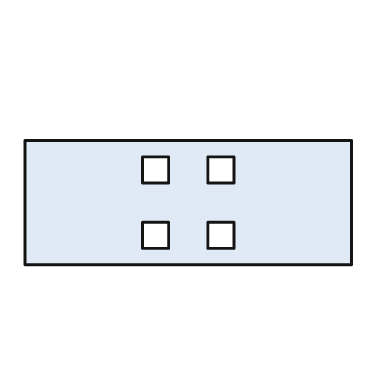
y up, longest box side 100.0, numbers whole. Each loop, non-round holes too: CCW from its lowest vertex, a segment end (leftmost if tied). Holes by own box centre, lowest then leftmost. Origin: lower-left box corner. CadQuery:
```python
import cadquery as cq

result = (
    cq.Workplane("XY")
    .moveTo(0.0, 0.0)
    .lineTo(100.0, 0.0)
    .lineTo(100.0, 38.0)
    .lineTo(0.0, 38.0)
    .close()
    .moveTo(36.0, 5.0)
    .lineTo(44.0, 5.0)
    .lineTo(44.0, 13.0)
    .lineTo(36.0, 13.0)
    .close()
    .moveTo(56.0, 5.0)
    .lineTo(64.0, 5.0)
    .lineTo(64.0, 13.0)
    .lineTo(56.0, 13.0)
    .close()
    .moveTo(36.0, 25.0)
    .lineTo(44.0, 25.0)
    .lineTo(44.0, 33.0)
    .lineTo(36.0, 33.0)
    .close()
    .moveTo(56.0, 25.0)
    .lineTo(64.0, 25.0)
    .lineTo(64.0, 33.0)
    .lineTo(56.0, 33.0)
    .close()
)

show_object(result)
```